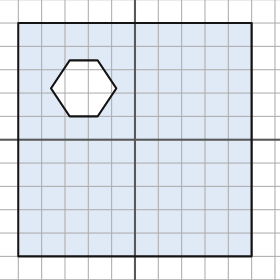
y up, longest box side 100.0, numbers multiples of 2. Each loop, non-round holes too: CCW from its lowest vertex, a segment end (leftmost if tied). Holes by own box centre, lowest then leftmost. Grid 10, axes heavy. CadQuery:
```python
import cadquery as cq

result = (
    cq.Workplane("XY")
    .moveTo(-50.0, -50.0)
    .lineTo(50.0, -50.0)
    .lineTo(50.0, 50.0)
    .lineTo(-50.0, 50.0)
    .close()
    .moveTo(-28.0, 10.0)
    .lineTo(-16.0, 10.0)
    .lineTo(-8.0, 22.0)
    .lineTo(-16.0, 34.0)
    .lineTo(-28.0, 34.0)
    .lineTo(-36.0, 22.0)
    .close()
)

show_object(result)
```